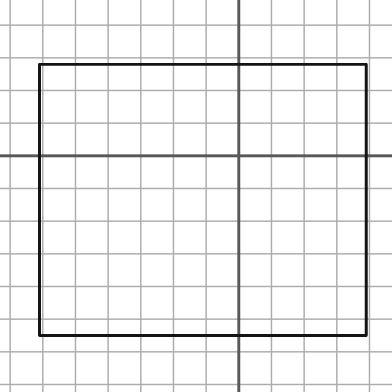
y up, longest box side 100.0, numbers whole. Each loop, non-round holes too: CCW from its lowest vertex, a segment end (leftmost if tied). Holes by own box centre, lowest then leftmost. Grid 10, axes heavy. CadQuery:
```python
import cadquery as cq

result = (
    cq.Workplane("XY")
    .moveTo(-61.0, -55.0)
    .lineTo(39.0, -55.0)
    .lineTo(39.0, 28.0)
    .lineTo(-61.0, 28.0)
    .close()
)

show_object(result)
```